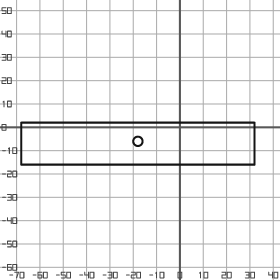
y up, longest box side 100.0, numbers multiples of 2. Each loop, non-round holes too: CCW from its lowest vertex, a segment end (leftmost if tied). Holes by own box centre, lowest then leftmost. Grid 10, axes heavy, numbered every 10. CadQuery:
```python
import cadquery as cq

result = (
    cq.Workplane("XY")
    .moveTo(-68.0, -16.0)
    .lineTo(32.0, -16.0)
    .lineTo(32.0, 2.0)
    .lineTo(-68.0, 2.0)
    .close()
    .moveTo(-18.0, -6.0)
    .circle(2.0)
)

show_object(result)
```